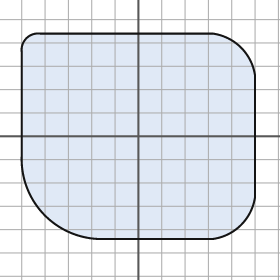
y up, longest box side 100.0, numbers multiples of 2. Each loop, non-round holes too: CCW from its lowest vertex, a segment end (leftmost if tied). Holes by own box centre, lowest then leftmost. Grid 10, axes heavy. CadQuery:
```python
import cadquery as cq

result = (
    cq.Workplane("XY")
    .moveTo(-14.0, -44.0)
    .lineTo(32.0, -44.0)
    .threePointArc((44.0, -38.0), (50.0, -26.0))
    .lineTo(50.0, 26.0)
    .threePointArc((44.0, 38.0), (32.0, 44.0))
    .lineTo(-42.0, 44.0)
    .threePointArc((-48.0, 42.0), (-50.0, 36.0))
    .lineTo(-50.0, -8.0)
    .threePointArc((-40.0, -34.0), (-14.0, -44.0))
    .close()
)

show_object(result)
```